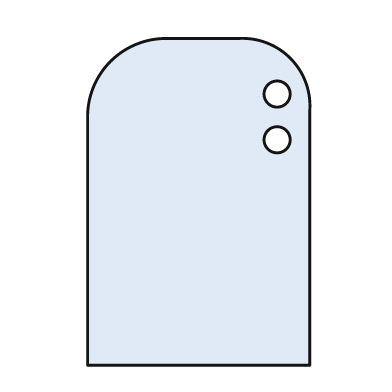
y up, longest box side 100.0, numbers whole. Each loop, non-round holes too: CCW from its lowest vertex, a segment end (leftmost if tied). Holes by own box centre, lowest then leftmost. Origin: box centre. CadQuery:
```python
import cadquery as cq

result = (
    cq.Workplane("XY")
    .moveTo(-34.0, -50.0)
    .lineTo(34.0, -50.0)
    .lineTo(34.0, 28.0)
    .threePointArc((28.0, 44.0), (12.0, 50.0))
    .lineTo(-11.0, 50.0)
    .threePointArc((-27.0, 43.0), (-34.0, 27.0))
    .close()
    .moveTo(24.0, 19.0)
    .circle(4.0)
    .moveTo(24.0, 33.0)
    .circle(4.0)
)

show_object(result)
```